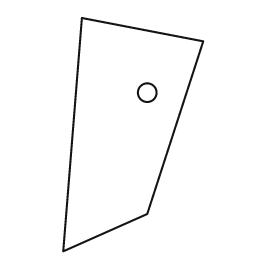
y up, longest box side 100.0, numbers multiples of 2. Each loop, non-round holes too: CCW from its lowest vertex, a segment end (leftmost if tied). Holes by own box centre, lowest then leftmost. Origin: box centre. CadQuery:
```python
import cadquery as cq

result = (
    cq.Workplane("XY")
    .moveTo(-30.0, -50.0)
    .lineTo(6.0, -34.0)
    .lineTo(30.0, 40.0)
    .lineTo(-22.0, 50.0)
    .close()
    .moveTo(6.0, 18.0)
    .circle(4.0)
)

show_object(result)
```